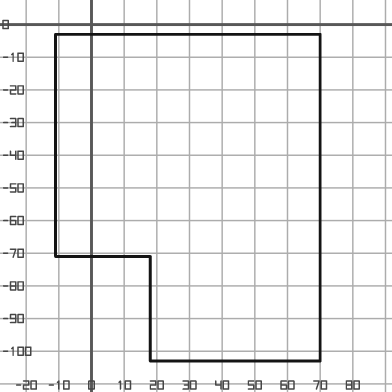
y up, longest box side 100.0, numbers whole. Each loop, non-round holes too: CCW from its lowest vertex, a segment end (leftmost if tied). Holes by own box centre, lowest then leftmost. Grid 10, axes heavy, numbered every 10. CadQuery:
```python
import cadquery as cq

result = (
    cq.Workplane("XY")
    .moveTo(18.0, -103.0)
    .lineTo(70.0, -103.0)
    .lineTo(70.0, -3.0)
    .lineTo(-11.0, -3.0)
    .lineTo(-11.0, -71.0)
    .lineTo(18.0, -71.0)
    .close()
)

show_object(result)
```